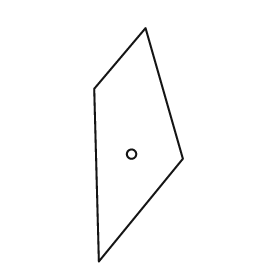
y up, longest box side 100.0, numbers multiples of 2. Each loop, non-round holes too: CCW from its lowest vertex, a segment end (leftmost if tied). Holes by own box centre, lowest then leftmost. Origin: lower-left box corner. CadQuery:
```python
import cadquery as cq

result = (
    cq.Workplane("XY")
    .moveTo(2.0, 0.0)
    .lineTo(38.0, 44.0)
    .lineTo(22.0, 100.0)
    .lineTo(0.0, 74.0)
    .close()
    .moveTo(16.0, 46.0)
    .circle(2.0)
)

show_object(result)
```